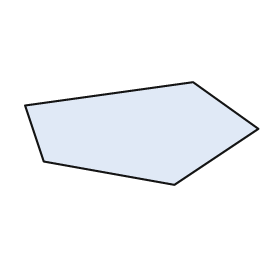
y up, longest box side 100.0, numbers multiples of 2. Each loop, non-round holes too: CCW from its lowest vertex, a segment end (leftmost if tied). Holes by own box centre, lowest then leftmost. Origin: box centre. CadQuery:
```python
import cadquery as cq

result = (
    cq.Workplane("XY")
    .moveTo(14.0, -22.0)
    .lineTo(50.0, 2.0)
    .lineTo(22.0, 22.0)
    .lineTo(-50.0, 12.0)
    .lineTo(-42.0, -12.0)
    .close()
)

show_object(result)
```